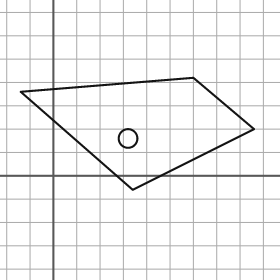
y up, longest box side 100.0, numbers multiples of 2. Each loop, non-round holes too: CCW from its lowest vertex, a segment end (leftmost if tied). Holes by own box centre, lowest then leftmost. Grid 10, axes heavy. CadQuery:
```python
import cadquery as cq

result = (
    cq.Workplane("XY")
    .moveTo(34.0, -6.0)
    .lineTo(86.0, 20.0)
    .lineTo(60.0, 42.0)
    .lineTo(-14.0, 36.0)
    .close()
    .moveTo(32.0, 16.0)
    .circle(4.0)
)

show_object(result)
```